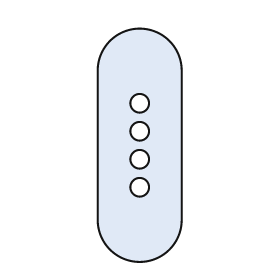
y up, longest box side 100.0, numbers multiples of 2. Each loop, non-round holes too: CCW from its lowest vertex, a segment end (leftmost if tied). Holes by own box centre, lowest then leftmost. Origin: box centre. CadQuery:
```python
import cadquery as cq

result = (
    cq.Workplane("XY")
    .moveTo(-18.0, -32.0)
    .threePointArc((0.0, -50.0), (18.0, -32.0))
    .lineTo(18.0, 32.0)
    .threePointArc((0.0, 50.0), (-18.0, 32.0))
    .close()
    .moveTo(0.0, -18.0)
    .circle(4.0)
    .moveTo(0.0, -6.0)
    .circle(4.0)
    .moveTo(0.0, 6.0)
    .circle(4.0)
    .moveTo(0.0, 18.0)
    .circle(4.0)
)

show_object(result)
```